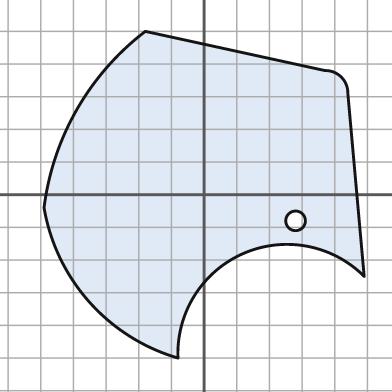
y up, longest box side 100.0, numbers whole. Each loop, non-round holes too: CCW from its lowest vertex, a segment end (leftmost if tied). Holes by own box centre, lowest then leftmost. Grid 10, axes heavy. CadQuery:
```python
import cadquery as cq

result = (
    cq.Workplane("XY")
    .moveTo(-8.0, -50.0)
    .threePointArc((12.0, -18.0), (49.0, -25.0))
    .lineTo(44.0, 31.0)
    .threePointArc((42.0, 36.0), (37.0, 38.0))
    .lineTo(-18.0, 50.0)
    .threePointArc((-39.0, 26.0), (-49.0, -4.0))
    .threePointArc((-35.0, -33.0), (-8.0, -50.0))
    .close()
    .moveTo(28.0, -8.0)
    .circle(3.0)
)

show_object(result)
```